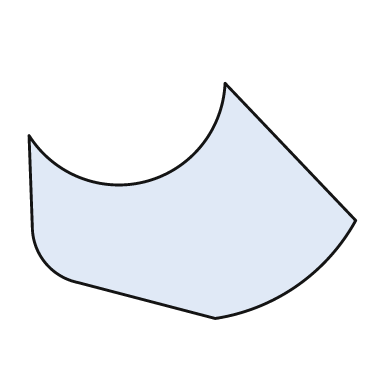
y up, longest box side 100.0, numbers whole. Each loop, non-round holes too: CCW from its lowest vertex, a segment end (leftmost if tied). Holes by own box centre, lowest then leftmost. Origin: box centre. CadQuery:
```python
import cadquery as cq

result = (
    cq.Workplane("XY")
    .moveTo(7.0, -36.0)
    .threePointArc((32.0, -26.0), (50.0, -6.0))
    .lineTo(10.0, 36.0)
    .threePointArc((-14.0, 6.0), (-50.0, 20.0))
    .lineTo(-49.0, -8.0)
    .threePointArc((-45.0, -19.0), (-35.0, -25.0))
    .close()
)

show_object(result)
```